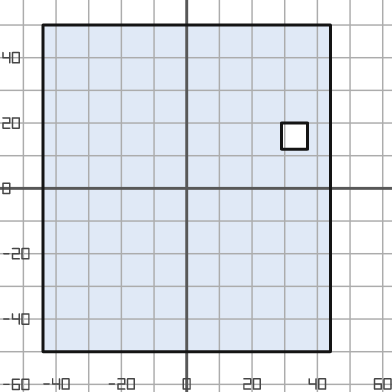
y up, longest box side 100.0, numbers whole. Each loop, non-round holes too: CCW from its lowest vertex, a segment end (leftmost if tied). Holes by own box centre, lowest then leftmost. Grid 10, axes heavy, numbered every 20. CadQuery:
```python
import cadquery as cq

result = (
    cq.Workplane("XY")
    .moveTo(-44.0, -50.0)
    .lineTo(44.0, -50.0)
    .lineTo(44.0, 50.0)
    .lineTo(-44.0, 50.0)
    .close()
    .moveTo(29.0, 12.0)
    .lineTo(37.0, 12.0)
    .lineTo(37.0, 20.0)
    .lineTo(29.0, 20.0)
    .close()
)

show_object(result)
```